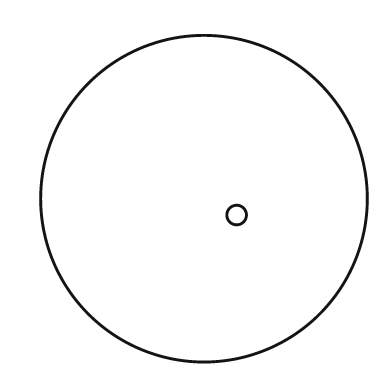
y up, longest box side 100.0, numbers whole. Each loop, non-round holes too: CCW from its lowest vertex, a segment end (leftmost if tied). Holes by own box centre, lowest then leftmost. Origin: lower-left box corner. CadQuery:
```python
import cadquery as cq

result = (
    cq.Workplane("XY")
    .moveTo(50.0, 50.0)
    .circle(50.0)
    .moveTo(60.0, 45.0)
    .circle(3.0)
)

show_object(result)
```